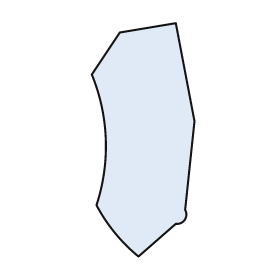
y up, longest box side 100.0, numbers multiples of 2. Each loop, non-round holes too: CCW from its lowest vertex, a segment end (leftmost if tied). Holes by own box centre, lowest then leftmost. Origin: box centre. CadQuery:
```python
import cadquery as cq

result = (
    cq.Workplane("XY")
    .moveTo(-2.0, -50.0)
    .lineTo(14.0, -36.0)
    .threePointArc((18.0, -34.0), (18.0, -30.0))
    .lineTo(22.0, 8.0)
    .lineTo(14.0, 50.0)
    .lineTo(-10.0, 46.0)
    .lineTo(-22.0, 28.0)
    .threePointArc((-16.0, 0.0), (-20.0, -28.0))
    .threePointArc((-12.0, -40.0), (-2.0, -50.0))
    .close()
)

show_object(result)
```